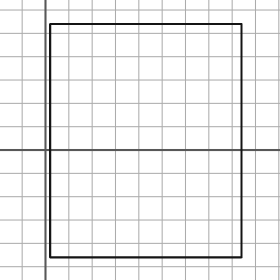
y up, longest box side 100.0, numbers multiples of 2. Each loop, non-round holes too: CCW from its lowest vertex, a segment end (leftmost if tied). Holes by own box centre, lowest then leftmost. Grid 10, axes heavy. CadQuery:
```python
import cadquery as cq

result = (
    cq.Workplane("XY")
    .moveTo(2.0, -46.0)
    .lineTo(84.0, -46.0)
    .lineTo(84.0, 54.0)
    .lineTo(2.0, 54.0)
    .close()
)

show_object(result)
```